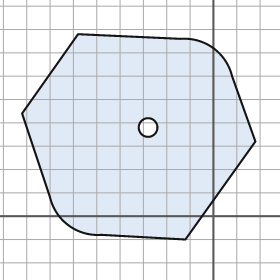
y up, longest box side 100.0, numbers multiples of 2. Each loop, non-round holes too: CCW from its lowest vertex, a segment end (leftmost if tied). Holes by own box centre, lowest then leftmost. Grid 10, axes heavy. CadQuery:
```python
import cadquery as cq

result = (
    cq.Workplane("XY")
    .moveTo(-12.0, -10.0)
    .lineTo(18.0, 32.0)
    .lineTo(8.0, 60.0)
    .threePointArc((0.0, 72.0), (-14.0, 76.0))
    .lineTo(-58.0, 78.0)
    .lineTo(-82.0, 44.0)
    .lineTo(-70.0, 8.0)
    .threePointArc((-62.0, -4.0), (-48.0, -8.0))
    .close()
    .moveTo(-28.0, 38.0)
    .circle(4.0)
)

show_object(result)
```